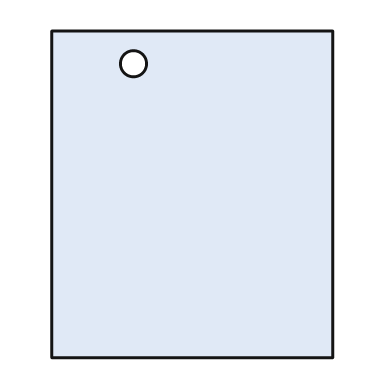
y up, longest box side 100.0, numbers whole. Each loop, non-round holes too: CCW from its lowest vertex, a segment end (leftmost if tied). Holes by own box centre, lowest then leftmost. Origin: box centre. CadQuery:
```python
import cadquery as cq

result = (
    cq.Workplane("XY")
    .moveTo(-43.0, -50.0)
    .lineTo(43.0, -50.0)
    .lineTo(43.0, 50.0)
    .lineTo(-43.0, 50.0)
    .close()
    .moveTo(-18.0, 40.0)
    .circle(4.0)
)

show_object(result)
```